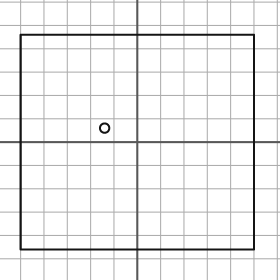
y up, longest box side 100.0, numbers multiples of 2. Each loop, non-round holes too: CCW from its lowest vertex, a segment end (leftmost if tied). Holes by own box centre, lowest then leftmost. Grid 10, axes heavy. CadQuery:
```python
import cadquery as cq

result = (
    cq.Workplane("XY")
    .moveTo(-50.0, -46.0)
    .lineTo(50.0, -46.0)
    .lineTo(50.0, 46.0)
    .lineTo(-50.0, 46.0)
    .close()
    .moveTo(-14.0, 6.0)
    .circle(2.0)
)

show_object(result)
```